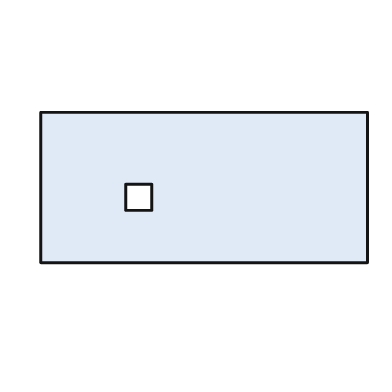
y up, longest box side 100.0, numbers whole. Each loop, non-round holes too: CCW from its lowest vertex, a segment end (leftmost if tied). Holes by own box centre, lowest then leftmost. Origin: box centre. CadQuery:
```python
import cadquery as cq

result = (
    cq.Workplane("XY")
    .moveTo(-50.0, -23.0)
    .lineTo(50.0, -23.0)
    .lineTo(50.0, 23.0)
    .lineTo(-50.0, 23.0)
    .close()
    .moveTo(-24.0, -7.0)
    .lineTo(-16.0, -7.0)
    .lineTo(-16.0, 1.0)
    .lineTo(-24.0, 1.0)
    .close()
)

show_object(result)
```